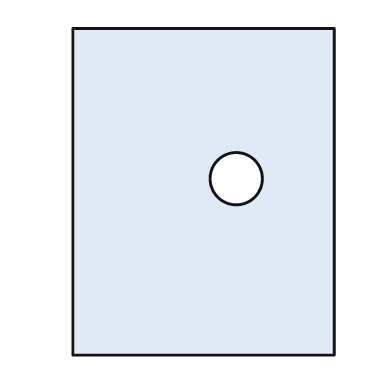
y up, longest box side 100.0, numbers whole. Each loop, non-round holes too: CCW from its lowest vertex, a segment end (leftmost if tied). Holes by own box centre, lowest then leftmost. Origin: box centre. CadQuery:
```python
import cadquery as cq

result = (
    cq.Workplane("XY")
    .moveTo(-40.0, -50.0)
    .lineTo(40.0, -50.0)
    .lineTo(40.0, 50.0)
    .lineTo(-40.0, 50.0)
    .close()
    .moveTo(10.0, 4.0)
    .circle(8.0)
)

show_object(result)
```